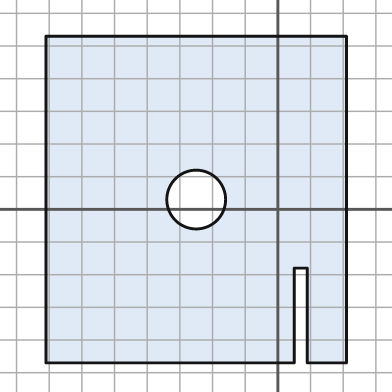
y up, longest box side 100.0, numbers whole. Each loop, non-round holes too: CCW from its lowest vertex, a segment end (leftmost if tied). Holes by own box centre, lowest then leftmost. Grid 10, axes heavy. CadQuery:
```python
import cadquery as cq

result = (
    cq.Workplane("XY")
    .moveTo(-71.0, -47.0)
    .lineTo(5.0, -47.0)
    .lineTo(5.0, -18.0)
    .lineTo(9.0, -18.0)
    .lineTo(9.0, -47.0)
    .lineTo(21.0, -47.0)
    .lineTo(21.0, 53.0)
    .lineTo(-71.0, 53.0)
    .close()
    .moveTo(-25.0, 3.0)
    .circle(9.0)
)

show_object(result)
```